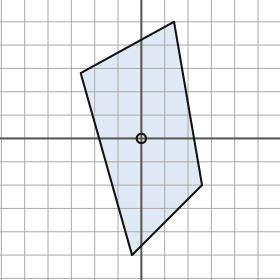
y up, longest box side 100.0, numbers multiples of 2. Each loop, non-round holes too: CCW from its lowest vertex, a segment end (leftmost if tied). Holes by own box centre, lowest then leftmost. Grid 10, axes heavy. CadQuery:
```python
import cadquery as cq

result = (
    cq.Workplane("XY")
    .moveTo(-4.0, -50.0)
    .lineTo(26.0, -20.0)
    .lineTo(14.0, 50.0)
    .lineTo(-26.0, 28.0)
    .close()
    .moveTo(0.0, 0.0)
    .circle(2.0)
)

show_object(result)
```